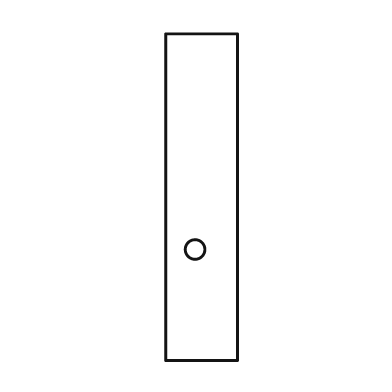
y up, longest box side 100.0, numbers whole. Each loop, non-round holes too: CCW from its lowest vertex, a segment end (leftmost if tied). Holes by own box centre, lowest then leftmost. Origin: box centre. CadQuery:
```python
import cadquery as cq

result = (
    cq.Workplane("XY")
    .moveTo(-11.0, -50.0)
    .lineTo(11.0, -50.0)
    .lineTo(11.0, 50.0)
    .lineTo(-11.0, 50.0)
    .close()
    .moveTo(-2.0, -16.0)
    .circle(3.0)
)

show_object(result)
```